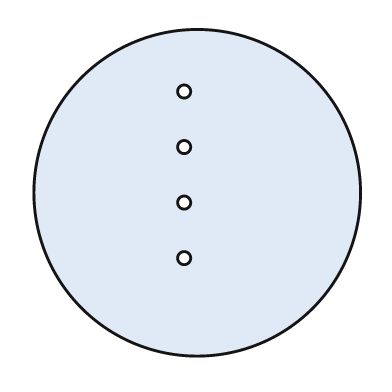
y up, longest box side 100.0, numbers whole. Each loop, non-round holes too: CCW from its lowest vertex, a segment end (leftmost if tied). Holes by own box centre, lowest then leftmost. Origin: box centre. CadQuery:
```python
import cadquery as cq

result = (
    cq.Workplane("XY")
    .moveTo(0.0, 0.0)
    .circle(50.0)
    .moveTo(-4.0, -20.0)
    .circle(2.0)
    .moveTo(-4.0, -3.0)
    .circle(2.0)
    .moveTo(-4.0, 14.0)
    .circle(2.0)
    .moveTo(-4.0, 31.0)
    .circle(2.0)
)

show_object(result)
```